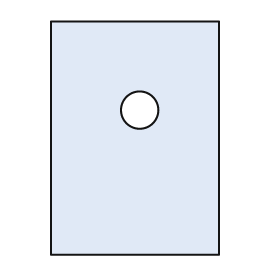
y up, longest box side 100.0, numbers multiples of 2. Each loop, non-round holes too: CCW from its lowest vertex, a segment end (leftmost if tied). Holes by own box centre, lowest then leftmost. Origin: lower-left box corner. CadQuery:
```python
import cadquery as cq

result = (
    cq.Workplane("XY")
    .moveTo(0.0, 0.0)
    .lineTo(72.0, 0.0)
    .lineTo(72.0, 100.0)
    .lineTo(0.0, 100.0)
    .close()
    .moveTo(38.0, 62.0)
    .circle(8.0)
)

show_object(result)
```